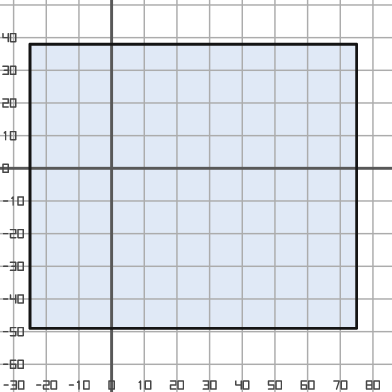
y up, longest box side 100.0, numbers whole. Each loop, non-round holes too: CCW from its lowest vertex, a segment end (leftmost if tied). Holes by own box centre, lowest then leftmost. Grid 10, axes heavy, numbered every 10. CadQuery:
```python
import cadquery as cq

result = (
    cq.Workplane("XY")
    .moveTo(-25.0, -49.0)
    .lineTo(75.0, -49.0)
    .lineTo(75.0, 38.0)
    .lineTo(-25.0, 38.0)
    .close()
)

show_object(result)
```